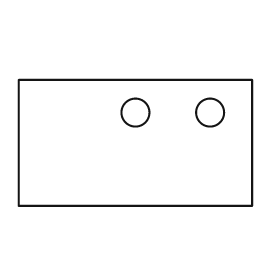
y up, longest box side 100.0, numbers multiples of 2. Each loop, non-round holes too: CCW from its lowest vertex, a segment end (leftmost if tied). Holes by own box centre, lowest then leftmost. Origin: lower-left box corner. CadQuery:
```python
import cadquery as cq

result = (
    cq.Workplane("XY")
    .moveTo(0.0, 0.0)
    .lineTo(100.0, 0.0)
    .lineTo(100.0, 54.0)
    .lineTo(0.0, 54.0)
    .close()
    .moveTo(50.0, 40.0)
    .circle(6.0)
    .moveTo(82.0, 40.0)
    .circle(6.0)
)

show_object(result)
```